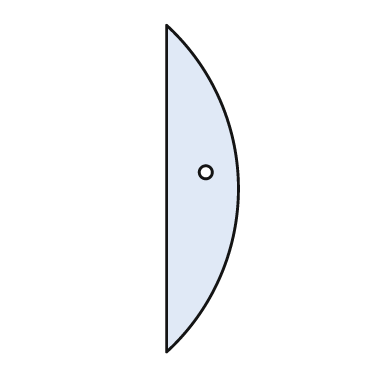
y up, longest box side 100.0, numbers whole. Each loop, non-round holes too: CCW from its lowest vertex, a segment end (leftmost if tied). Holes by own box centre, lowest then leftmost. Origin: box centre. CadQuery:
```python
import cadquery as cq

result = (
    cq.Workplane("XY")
    .moveTo(-11.0, -50.0)
    .threePointArc((11.0, 0.0), (-11.0, 50.0))
    .close()
    .moveTo(1.0, 5.0)
    .circle(2.0)
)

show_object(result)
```